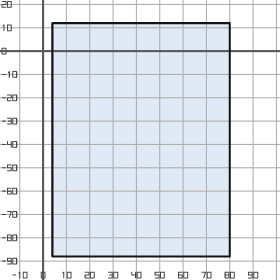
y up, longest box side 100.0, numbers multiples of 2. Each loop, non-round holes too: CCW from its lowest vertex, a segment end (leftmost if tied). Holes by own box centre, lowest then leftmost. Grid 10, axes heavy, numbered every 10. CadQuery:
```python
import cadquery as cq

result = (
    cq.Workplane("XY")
    .moveTo(4.0, -88.0)
    .lineTo(80.0, -88.0)
    .lineTo(80.0, 12.0)
    .lineTo(4.0, 12.0)
    .close()
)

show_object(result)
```